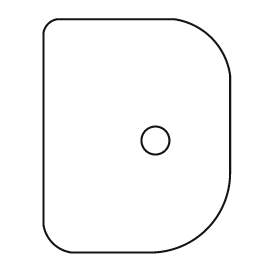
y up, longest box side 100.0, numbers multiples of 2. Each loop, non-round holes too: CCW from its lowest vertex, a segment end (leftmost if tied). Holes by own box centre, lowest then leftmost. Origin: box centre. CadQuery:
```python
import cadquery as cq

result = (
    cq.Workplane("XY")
    .moveTo(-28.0, -50.0)
    .lineTo(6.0, -50.0)
    .threePointArc((30.0, -40.0), (40.0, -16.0))
    .lineTo(40.0, 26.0)
    .threePointArc((32.0, 42.0), (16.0, 50.0))
    .lineTo(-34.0, 50.0)
    .threePointArc((-38.0, 48.0), (-40.0, 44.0))
    .lineTo(-40.0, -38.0)
    .threePointArc((-36.0, -46.0), (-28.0, -50.0))
    .close()
    .moveTo(8.0, -2.0)
    .circle(6.0)
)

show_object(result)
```